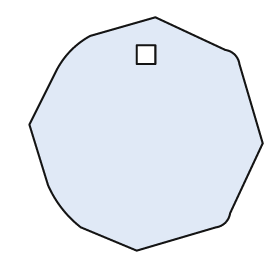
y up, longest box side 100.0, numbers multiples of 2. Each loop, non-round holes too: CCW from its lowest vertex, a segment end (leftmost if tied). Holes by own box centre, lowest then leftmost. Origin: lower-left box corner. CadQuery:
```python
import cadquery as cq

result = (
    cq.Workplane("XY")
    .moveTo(46.0, 0.0)
    .lineTo(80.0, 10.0)
    .threePointArc((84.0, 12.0), (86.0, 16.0))
    .lineTo(100.0, 46.0)
    .lineTo(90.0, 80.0)
    .threePointArc((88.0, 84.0), (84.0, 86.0))
    .lineTo(54.0, 100.0)
    .lineTo(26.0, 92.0)
    .threePointArc((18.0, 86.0), (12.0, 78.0))
    .lineTo(0.0, 54.0)
    .lineTo(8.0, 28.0)
    .threePointArc((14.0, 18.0), (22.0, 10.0))
    .close()
    .moveTo(46.0, 80.0)
    .lineTo(54.0, 80.0)
    .lineTo(54.0, 88.0)
    .lineTo(46.0, 88.0)
    .close()
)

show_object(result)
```